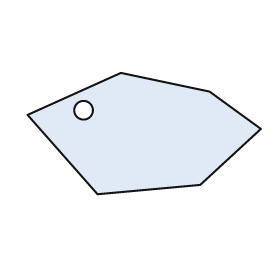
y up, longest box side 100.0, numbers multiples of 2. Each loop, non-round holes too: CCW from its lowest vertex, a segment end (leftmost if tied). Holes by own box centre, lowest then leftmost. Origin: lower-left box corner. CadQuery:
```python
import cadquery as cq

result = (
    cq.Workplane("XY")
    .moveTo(30.0, 0.0)
    .lineTo(74.0, 4.0)
    .lineTo(100.0, 28.0)
    .lineTo(78.0, 44.0)
    .lineTo(40.0, 52.0)
    .lineTo(0.0, 34.0)
    .close()
    .moveTo(24.0, 36.0)
    .circle(4.0)
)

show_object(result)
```